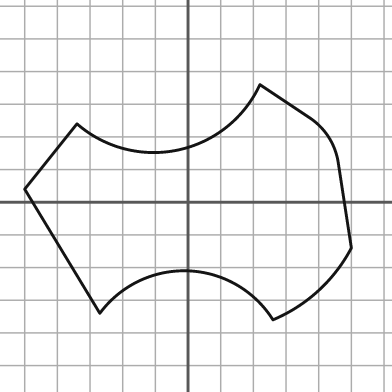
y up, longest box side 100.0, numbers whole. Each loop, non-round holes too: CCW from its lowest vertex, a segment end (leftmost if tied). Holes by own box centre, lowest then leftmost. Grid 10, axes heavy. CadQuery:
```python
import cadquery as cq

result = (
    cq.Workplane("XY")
    .moveTo(26.0, -36.0)
    .threePointArc((40.0, -27.0), (50.0, -14.0))
    .lineTo(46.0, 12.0)
    .threePointArc((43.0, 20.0), (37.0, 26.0))
    .lineTo(22.0, 36.0)
    .threePointArc((-3.0, 16.0), (-34.0, 24.0))
    .lineTo(-50.0, 4.0)
    .lineTo(-27.0, -34.0)
    .threePointArc((0.0, -21.0), (26.0, -36.0))
    .close()
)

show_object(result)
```